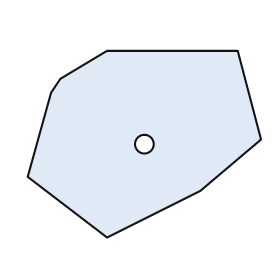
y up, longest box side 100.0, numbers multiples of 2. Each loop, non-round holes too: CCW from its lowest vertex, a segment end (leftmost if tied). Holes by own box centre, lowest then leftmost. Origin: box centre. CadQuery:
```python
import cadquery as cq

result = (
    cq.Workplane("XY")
    .moveTo(-16.0, -40.0)
    .lineTo(24.0, -20.0)
    .lineTo(50.0, 2.0)
    .lineTo(40.0, 40.0)
    .lineTo(-16.0, 40.0)
    .lineTo(-36.0, 28.0)
    .lineTo(-40.0, 22.0)
    .lineTo(-50.0, -14.0)
    .close()
    .moveTo(0.0, 0.0)
    .circle(4.0)
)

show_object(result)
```